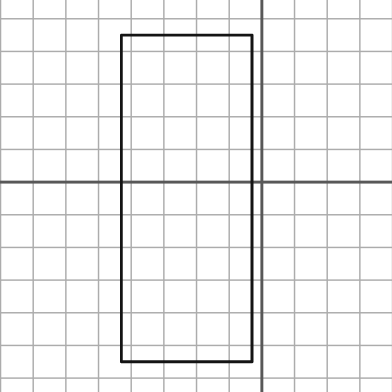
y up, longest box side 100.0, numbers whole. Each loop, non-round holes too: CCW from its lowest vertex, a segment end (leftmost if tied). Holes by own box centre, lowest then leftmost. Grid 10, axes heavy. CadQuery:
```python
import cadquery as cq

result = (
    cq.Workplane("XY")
    .moveTo(-43.0, -55.0)
    .lineTo(-3.0, -55.0)
    .lineTo(-3.0, 45.0)
    .lineTo(-43.0, 45.0)
    .close()
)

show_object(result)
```